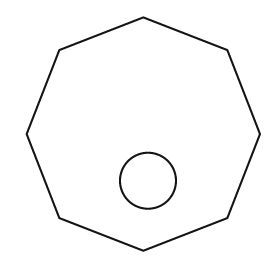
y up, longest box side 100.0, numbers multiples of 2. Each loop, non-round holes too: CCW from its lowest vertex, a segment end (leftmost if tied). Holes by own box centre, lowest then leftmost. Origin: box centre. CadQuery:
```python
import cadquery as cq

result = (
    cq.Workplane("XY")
    .moveTo(0.0, -50.0)
    .lineTo(36.0, -36.0)
    .lineTo(50.0, 0.0)
    .lineTo(36.0, 36.0)
    .lineTo(0.0, 50.0)
    .lineTo(-36.0, 36.0)
    .lineTo(-50.0, 0.0)
    .lineTo(-36.0, -36.0)
    .close()
    .moveTo(2.0, -20.0)
    .circle(12.0)
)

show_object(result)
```